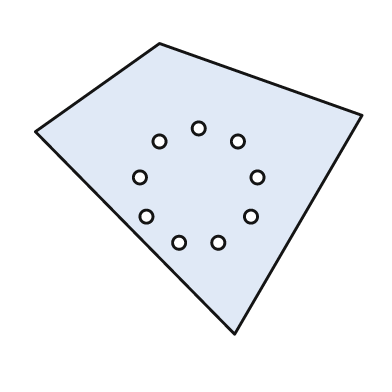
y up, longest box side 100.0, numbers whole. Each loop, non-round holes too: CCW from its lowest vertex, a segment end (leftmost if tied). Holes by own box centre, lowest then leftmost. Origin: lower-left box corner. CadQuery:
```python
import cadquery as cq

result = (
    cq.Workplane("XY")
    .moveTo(61.0, 0.0)
    .lineTo(100.0, 67.0)
    .lineTo(38.0, 89.0)
    .lineTo(0.0, 62.0)
    .close()
    .moveTo(44.0, 28.0)
    .circle(2.0)
    .moveTo(56.0, 28.0)
    .circle(2.0)
    .moveTo(34.0, 36.0)
    .circle(2.0)
    .moveTo(66.0, 36.0)
    .circle(2.0)
    .moveTo(32.0, 48.0)
    .circle(2.0)
    .moveTo(68.0, 48.0)
    .circle(2.0)
    .moveTo(38.0, 59.0)
    .circle(2.0)
    .moveTo(62.0, 59.0)
    .circle(2.0)
    .moveTo(50.0, 63.0)
    .circle(2.0)
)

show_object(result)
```